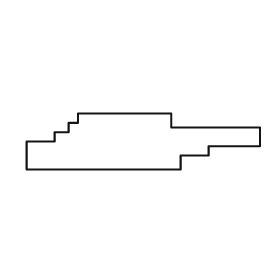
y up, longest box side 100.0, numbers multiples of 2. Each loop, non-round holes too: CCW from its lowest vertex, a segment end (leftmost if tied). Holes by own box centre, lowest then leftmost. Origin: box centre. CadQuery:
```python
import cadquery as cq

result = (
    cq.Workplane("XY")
    .moveTo(-50.0, -12.0)
    .lineTo(16.0, -12.0)
    .lineTo(16.0, -6.0)
    .lineTo(28.0, -6.0)
    .lineTo(28.0, -2.0)
    .lineTo(50.0, -2.0)
    .lineTo(50.0, 6.0)
    .lineTo(12.0, 6.0)
    .lineTo(12.0, 12.0)
    .lineTo(-28.0, 12.0)
    .lineTo(-28.0, 8.0)
    .lineTo(-32.0, 8.0)
    .lineTo(-32.0, 4.0)
    .lineTo(-38.0, 4.0)
    .lineTo(-38.0, 0.0)
    .lineTo(-50.0, 0.0)
    .close()
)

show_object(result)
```